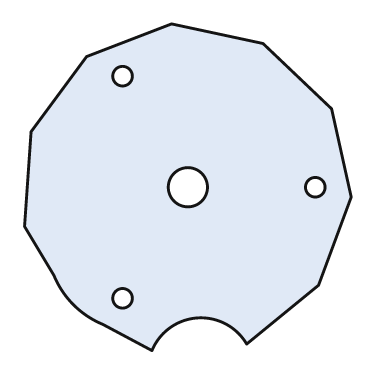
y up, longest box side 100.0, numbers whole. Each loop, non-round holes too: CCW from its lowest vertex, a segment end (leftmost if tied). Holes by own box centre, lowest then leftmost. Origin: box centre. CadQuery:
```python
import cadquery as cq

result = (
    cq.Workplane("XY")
    .moveTo(-11.0, -50.0)
    .threePointArc((3.0, -40.0), (18.0, -48.0))
    .lineTo(40.0, -30.0)
    .lineTo(50.0, -3.0)
    .lineTo(44.0, 24.0)
    .lineTo(23.0, 44.0)
    .lineTo(-5.0, 50.0)
    .lineTo(-31.0, 40.0)
    .lineTo(-48.0, 17.0)
    .lineTo(-50.0, -12.0)
    .lineTo(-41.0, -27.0)
    .threePointArc((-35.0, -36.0), (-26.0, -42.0))
    .close()
    .moveTo(-20.0, -34.0)
    .circle(3.0)
    .moveTo(0.0, 0.0)
    .circle(6.0)
    .moveTo(39.0, 0.0)
    .circle(3.0)
    .moveTo(-20.0, 34.0)
    .circle(3.0)
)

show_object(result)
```